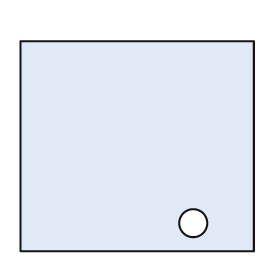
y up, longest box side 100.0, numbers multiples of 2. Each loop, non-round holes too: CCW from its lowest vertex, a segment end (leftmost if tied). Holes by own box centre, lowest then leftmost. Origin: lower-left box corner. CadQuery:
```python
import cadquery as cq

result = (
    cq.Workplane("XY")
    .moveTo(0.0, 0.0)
    .lineTo(100.0, 0.0)
    .lineTo(100.0, 90.0)
    .lineTo(0.0, 90.0)
    .close()
    .moveTo(74.0, 12.0)
    .circle(6.0)
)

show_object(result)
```